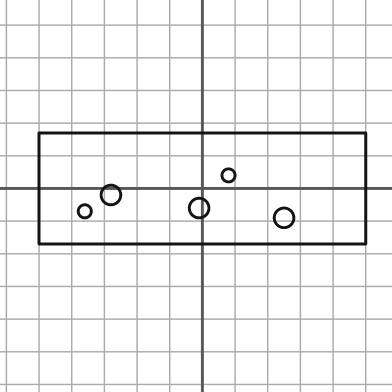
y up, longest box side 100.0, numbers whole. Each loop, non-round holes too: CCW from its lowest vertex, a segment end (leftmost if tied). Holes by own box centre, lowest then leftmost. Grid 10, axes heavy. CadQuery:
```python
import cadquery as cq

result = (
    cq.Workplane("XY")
    .moveTo(-50.0, -17.0)
    .lineTo(50.0, -17.0)
    .lineTo(50.0, 17.0)
    .lineTo(-50.0, 17.0)
    .close()
    .moveTo(25.0, -9.0)
    .circle(3.0)
    .moveTo(-36.0, -7.0)
    .circle(2.0)
    .moveTo(-1.0, -6.0)
    .circle(3.0)
    .moveTo(-28.0, -2.0)
    .circle(3.0)
    .moveTo(8.0, 4.0)
    .circle(2.0)
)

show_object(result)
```